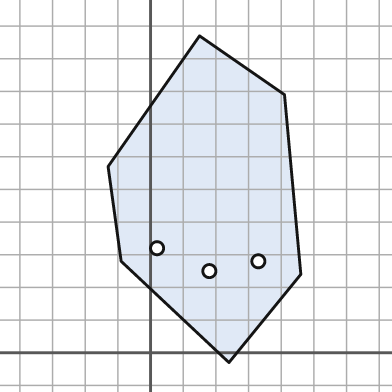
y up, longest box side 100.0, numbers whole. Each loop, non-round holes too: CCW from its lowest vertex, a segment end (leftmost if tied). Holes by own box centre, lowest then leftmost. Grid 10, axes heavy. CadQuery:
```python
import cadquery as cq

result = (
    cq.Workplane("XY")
    .moveTo(24.0, -3.0)
    .lineTo(46.0, 24.0)
    .lineTo(41.0, 79.0)
    .lineTo(15.0, 97.0)
    .lineTo(-13.0, 57.0)
    .lineTo(-9.0, 28.0)
    .close()
    .moveTo(18.0, 25.0)
    .circle(2.0)
    .moveTo(33.0, 28.0)
    .circle(2.0)
    .moveTo(2.0, 32.0)
    .circle(2.0)
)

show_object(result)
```